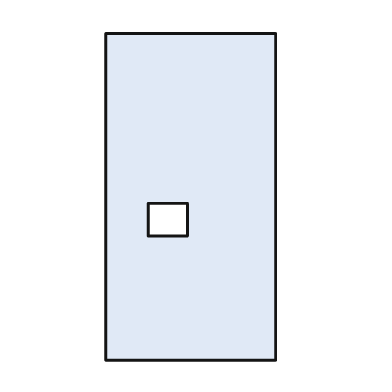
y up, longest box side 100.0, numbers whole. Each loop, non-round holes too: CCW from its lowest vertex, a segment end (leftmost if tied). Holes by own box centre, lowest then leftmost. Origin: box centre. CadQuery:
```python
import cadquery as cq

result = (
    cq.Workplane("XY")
    .moveTo(-26.0, -50.0)
    .lineTo(26.0, -50.0)
    .lineTo(26.0, 50.0)
    .lineTo(-26.0, 50.0)
    .close()
    .moveTo(-13.0, -12.0)
    .lineTo(-1.0, -12.0)
    .lineTo(-1.0, -2.0)
    .lineTo(-13.0, -2.0)
    .close()
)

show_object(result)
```